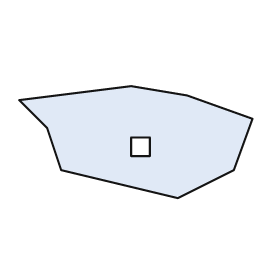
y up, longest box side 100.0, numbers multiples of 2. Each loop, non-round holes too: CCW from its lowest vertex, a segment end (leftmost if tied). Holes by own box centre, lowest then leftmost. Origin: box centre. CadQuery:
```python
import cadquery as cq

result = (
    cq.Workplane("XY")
    .moveTo(18.0, -24.0)
    .lineTo(42.0, -12.0)
    .lineTo(50.0, 10.0)
    .lineTo(22.0, 20.0)
    .lineTo(-2.0, 24.0)
    .lineTo(-50.0, 18.0)
    .lineTo(-38.0, 6.0)
    .lineTo(-32.0, -12.0)
    .close()
    .moveTo(-2.0, -6.0)
    .lineTo(6.0, -6.0)
    .lineTo(6.0, 2.0)
    .lineTo(-2.0, 2.0)
    .close()
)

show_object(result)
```